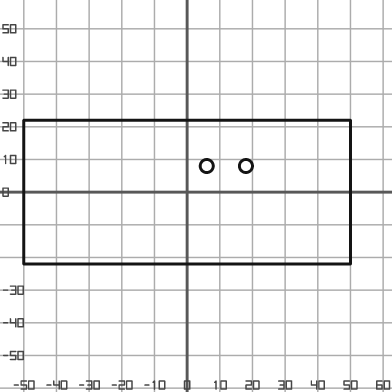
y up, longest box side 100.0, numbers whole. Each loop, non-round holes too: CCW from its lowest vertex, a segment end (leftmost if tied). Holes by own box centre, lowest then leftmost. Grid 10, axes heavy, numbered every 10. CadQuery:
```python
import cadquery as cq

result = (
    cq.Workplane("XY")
    .moveTo(-50.0, -22.0)
    .lineTo(50.0, -22.0)
    .lineTo(50.0, 22.0)
    .lineTo(-50.0, 22.0)
    .close()
    .moveTo(6.0, 8.0)
    .circle(2.0)
    .moveTo(18.0, 8.0)
    .circle(2.0)
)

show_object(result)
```